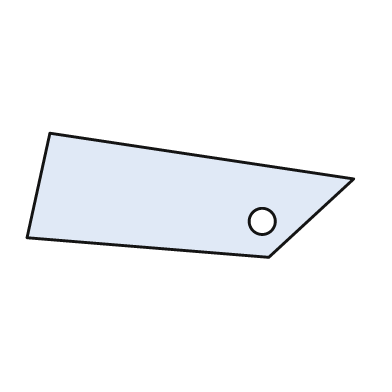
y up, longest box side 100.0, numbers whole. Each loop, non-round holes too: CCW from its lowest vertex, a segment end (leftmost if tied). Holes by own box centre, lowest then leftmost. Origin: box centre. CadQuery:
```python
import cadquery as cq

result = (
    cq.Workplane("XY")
    .moveTo(24.0, -19.0)
    .lineTo(50.0, 5.0)
    .lineTo(-43.0, 19.0)
    .lineTo(-50.0, -13.0)
    .close()
    .moveTo(22.0, -8.0)
    .circle(4.0)
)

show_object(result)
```